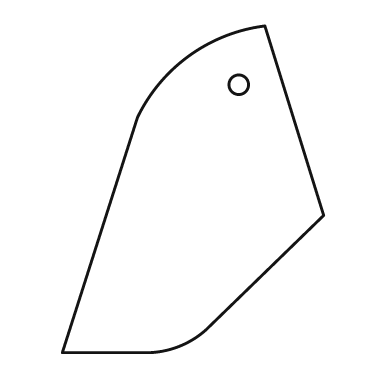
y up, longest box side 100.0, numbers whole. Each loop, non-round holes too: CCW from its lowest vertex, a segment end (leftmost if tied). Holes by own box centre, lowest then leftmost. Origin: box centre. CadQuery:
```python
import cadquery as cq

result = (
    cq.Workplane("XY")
    .moveTo(-40.0, -50.0)
    .lineTo(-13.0, -50.0)
    .threePointArc((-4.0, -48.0), (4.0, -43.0))
    .lineTo(40.0, -8.0)
    .lineTo(22.0, 50.0)
    .threePointArc((-1.0, 41.0), (-17.0, 22.0))
    .close()
    .moveTo(14.0, 32.0)
    .circle(3.0)
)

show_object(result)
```